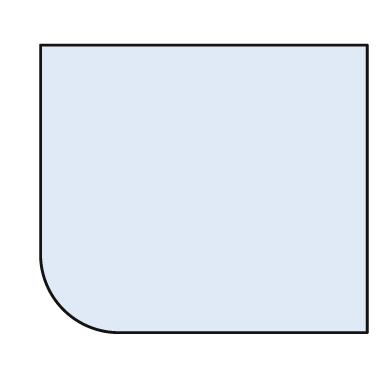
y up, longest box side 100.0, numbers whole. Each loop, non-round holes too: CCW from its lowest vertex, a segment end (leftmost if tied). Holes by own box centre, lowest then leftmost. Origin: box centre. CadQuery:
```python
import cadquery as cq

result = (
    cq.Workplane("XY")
    .moveTo(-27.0, -44.0)
    .lineTo(50.0, -44.0)
    .lineTo(50.0, 44.0)
    .lineTo(-50.0, 44.0)
    .lineTo(-50.0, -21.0)
    .threePointArc((-43.0, -37.0), (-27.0, -44.0))
    .close()
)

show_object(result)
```